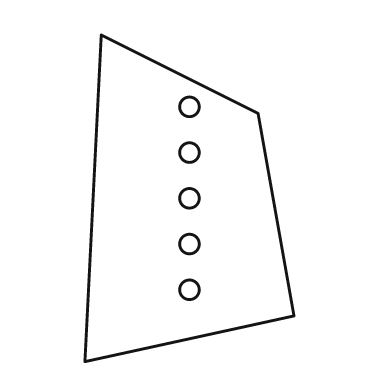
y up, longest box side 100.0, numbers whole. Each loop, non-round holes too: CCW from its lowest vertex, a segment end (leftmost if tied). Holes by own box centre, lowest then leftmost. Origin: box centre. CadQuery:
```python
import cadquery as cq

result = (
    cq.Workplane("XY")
    .moveTo(-32.0, -50.0)
    .lineTo(32.0, -36.0)
    .lineTo(21.0, 26.0)
    .lineTo(-27.0, 50.0)
    .close()
    .moveTo(0.0, -28.0)
    .circle(3.0)
    .moveTo(0.0, -14.0)
    .circle(3.0)
    .moveTo(0.0, 0.0)
    .circle(3.0)
    .moveTo(0.0, 14.0)
    .circle(3.0)
    .moveTo(0.0, 28.0)
    .circle(3.0)
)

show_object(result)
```